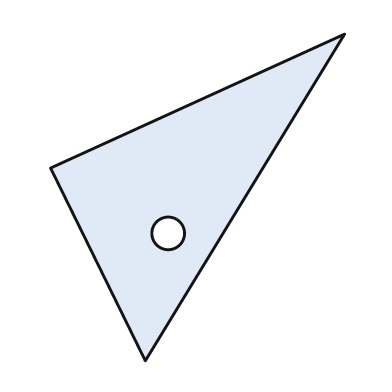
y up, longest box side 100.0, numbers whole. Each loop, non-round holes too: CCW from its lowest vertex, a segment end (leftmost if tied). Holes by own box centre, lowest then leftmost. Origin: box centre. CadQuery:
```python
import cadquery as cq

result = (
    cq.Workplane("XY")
    .moveTo(-16.0, -50.0)
    .lineTo(45.0, 50.0)
    .lineTo(-45.0, 9.0)
    .close()
    .moveTo(-9.0, -11.0)
    .circle(5.0)
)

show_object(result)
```